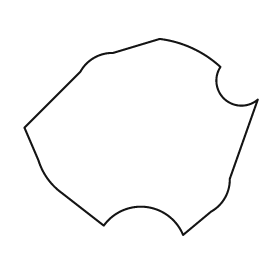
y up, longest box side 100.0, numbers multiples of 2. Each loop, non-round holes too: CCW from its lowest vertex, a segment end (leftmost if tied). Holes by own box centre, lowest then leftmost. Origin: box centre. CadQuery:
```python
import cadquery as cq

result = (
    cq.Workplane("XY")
    .moveTo(18.0, -42.0)
    .lineTo(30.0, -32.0)
    .threePointArc((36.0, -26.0), (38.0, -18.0))
    .lineTo(50.0, 16.0)
    .threePointArc((36.0, 16.0), (34.0, 30.0))
    .threePointArc((22.0, 38.0), (8.0, 42.0))
    .lineTo(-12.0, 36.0)
    .threePointArc((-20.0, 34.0), (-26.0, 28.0))
    .lineTo(-50.0, 4.0)
    .lineTo(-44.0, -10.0)
    .threePointArc((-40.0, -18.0), (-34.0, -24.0))
    .lineTo(-16.0, -38.0)
    .threePointArc((2.0, -30.0), (18.0, -42.0))
    .close()
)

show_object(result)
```